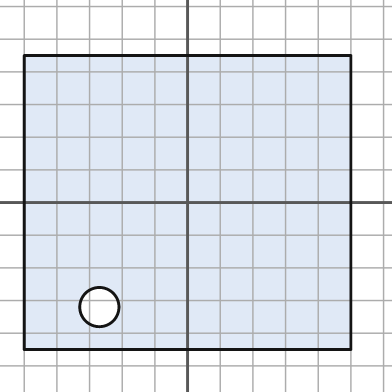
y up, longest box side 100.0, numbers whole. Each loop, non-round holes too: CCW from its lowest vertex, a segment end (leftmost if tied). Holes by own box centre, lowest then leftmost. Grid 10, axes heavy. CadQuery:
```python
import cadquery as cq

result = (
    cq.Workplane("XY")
    .moveTo(-50.0, -45.0)
    .lineTo(50.0, -45.0)
    .lineTo(50.0, 45.0)
    .lineTo(-50.0, 45.0)
    .close()
    .moveTo(-27.0, -32.0)
    .circle(6.0)
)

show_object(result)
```